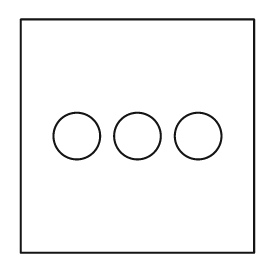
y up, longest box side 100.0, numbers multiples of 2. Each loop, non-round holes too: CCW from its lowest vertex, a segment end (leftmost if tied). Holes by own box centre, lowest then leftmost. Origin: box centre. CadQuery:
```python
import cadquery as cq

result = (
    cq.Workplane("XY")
    .moveTo(-50.0, -50.0)
    .lineTo(50.0, -50.0)
    .lineTo(50.0, 50.0)
    .lineTo(-50.0, 50.0)
    .close()
    .moveTo(-26.0, 0.0)
    .circle(10.0)
    .moveTo(0.0, 0.0)
    .circle(10.0)
    .moveTo(26.0, 0.0)
    .circle(10.0)
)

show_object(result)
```